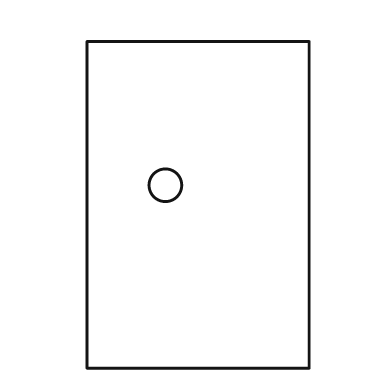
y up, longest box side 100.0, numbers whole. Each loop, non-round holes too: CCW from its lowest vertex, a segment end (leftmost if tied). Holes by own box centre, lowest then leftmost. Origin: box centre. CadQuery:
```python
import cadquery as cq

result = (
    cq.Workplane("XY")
    .moveTo(-34.0, -50.0)
    .lineTo(34.0, -50.0)
    .lineTo(34.0, 50.0)
    .lineTo(-34.0, 50.0)
    .close()
    .moveTo(-10.0, 6.0)
    .circle(5.0)
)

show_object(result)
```